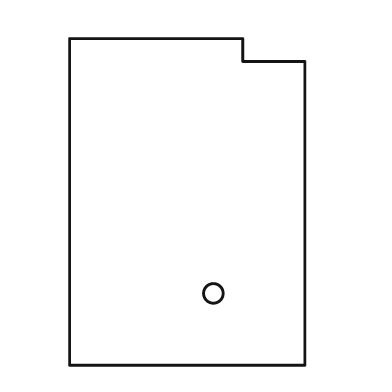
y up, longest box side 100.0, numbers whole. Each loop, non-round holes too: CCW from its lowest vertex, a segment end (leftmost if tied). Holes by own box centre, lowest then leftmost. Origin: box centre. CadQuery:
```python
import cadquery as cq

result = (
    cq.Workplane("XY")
    .moveTo(-36.0, -50.0)
    .lineTo(36.0, -50.0)
    .lineTo(36.0, 43.0)
    .lineTo(17.0, 43.0)
    .lineTo(17.0, 50.0)
    .lineTo(-36.0, 50.0)
    .close()
    .moveTo(8.0, -28.0)
    .circle(3.0)
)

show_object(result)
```